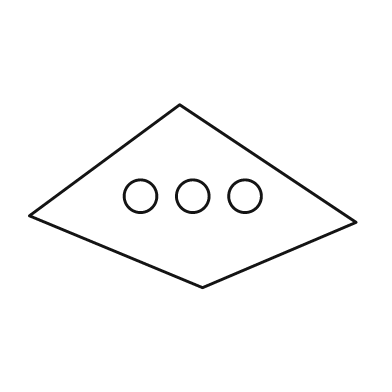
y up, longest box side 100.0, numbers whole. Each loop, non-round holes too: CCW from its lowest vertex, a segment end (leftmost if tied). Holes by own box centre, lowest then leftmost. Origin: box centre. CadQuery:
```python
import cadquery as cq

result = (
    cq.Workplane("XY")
    .moveTo(3.0, -28.0)
    .lineTo(50.0, -8.0)
    .lineTo(-4.0, 28.0)
    .lineTo(-50.0, -6.0)
    .close()
    .moveTo(-16.0, 0.0)
    .circle(5.0)
    .moveTo(0.0, 0.0)
    .circle(5.0)
    .moveTo(16.0, 0.0)
    .circle(5.0)
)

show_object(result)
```